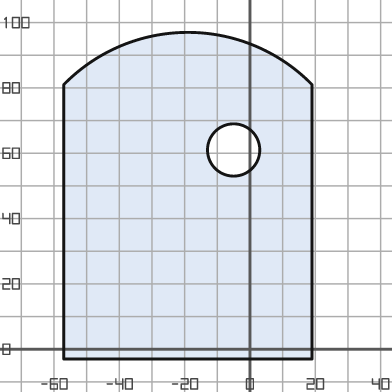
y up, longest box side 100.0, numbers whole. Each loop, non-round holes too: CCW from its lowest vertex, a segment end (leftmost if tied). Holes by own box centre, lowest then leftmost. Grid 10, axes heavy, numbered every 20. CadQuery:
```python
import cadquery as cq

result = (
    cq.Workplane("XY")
    .moveTo(-57.0, -3.0)
    .lineTo(19.0, -3.0)
    .lineTo(19.0, 81.0)
    .threePointArc((-19.0, 97.0), (-57.0, 81.0))
    .close()
    .moveTo(-5.0, 61.0)
    .circle(8.0)
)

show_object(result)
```